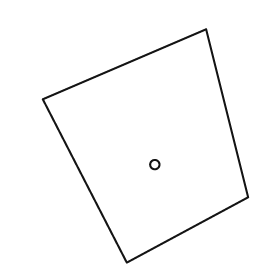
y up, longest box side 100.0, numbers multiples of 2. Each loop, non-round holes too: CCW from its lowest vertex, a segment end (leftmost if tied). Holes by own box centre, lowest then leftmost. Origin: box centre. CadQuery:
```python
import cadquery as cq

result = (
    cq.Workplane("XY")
    .moveTo(-8.0, -50.0)
    .lineTo(44.0, -22.0)
    .lineTo(26.0, 50.0)
    .lineTo(-44.0, 20.0)
    .close()
    .moveTo(4.0, -8.0)
    .circle(2.0)
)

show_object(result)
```